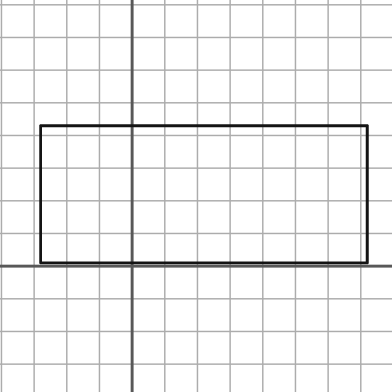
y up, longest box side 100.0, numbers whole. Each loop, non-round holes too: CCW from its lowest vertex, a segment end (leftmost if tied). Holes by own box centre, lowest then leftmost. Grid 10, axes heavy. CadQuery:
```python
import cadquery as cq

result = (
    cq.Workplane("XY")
    .moveTo(-28.0, 1.0)
    .lineTo(72.0, 1.0)
    .lineTo(72.0, 43.0)
    .lineTo(-28.0, 43.0)
    .close()
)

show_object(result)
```